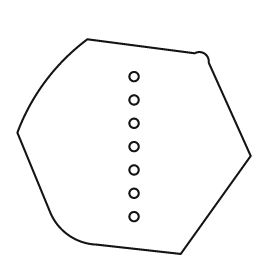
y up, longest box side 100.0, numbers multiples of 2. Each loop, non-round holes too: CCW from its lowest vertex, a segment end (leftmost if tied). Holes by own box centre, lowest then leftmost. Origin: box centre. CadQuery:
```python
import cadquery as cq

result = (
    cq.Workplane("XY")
    .moveTo(20.0, -46.0)
    .lineTo(50.0, -4.0)
    .lineTo(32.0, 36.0)
    .threePointArc((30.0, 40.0), (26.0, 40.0))
    .lineTo(-20.0, 46.0)
    .threePointArc((-38.0, 28.0), (-50.0, 6.0))
    .lineTo(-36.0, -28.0)
    .threePointArc((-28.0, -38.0), (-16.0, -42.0))
    .close()
    .moveTo(0.0, -30.0)
    .circle(2.0)
    .moveTo(0.0, -20.0)
    .circle(2.0)
    .moveTo(0.0, -10.0)
    .circle(2.0)
    .moveTo(0.0, 0.0)
    .circle(2.0)
    .moveTo(0.0, 10.0)
    .circle(2.0)
    .moveTo(0.0, 20.0)
    .circle(2.0)
    .moveTo(0.0, 30.0)
    .circle(2.0)
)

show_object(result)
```